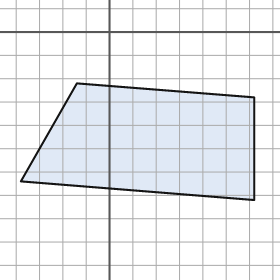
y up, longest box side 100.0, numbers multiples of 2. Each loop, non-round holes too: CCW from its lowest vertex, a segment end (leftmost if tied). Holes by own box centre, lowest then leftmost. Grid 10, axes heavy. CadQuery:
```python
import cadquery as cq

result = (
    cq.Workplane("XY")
    .moveTo(62.0, -72.0)
    .lineTo(62.0, -28.0)
    .lineTo(-14.0, -22.0)
    .lineTo(-38.0, -64.0)
    .close()
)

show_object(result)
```